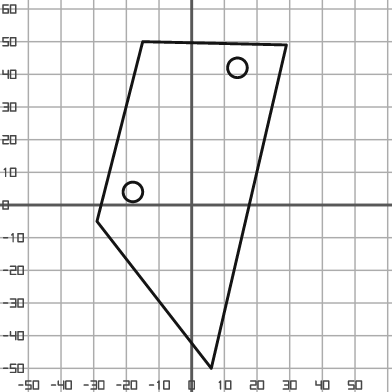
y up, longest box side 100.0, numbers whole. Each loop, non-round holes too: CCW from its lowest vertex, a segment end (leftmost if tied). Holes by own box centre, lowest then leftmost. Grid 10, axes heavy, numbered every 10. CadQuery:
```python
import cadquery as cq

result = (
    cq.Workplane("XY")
    .moveTo(6.0, -50.0)
    .lineTo(29.0, 49.0)
    .lineTo(-15.0, 50.0)
    .lineTo(-29.0, -5.0)
    .close()
    .moveTo(-18.0, 4.0)
    .circle(3.0)
    .moveTo(14.0, 42.0)
    .circle(3.0)
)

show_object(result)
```